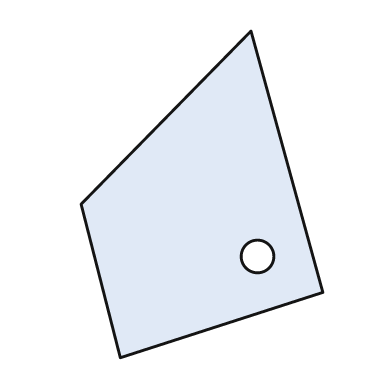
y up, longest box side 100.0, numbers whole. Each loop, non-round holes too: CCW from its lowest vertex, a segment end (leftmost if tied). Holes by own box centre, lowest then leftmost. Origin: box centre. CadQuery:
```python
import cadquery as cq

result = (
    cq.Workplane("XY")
    .moveTo(-25.0, -50.0)
    .lineTo(37.0, -30.0)
    .lineTo(15.0, 50.0)
    .lineTo(-37.0, -3.0)
    .close()
    .moveTo(17.0, -19.0)
    .circle(5.0)
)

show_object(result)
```